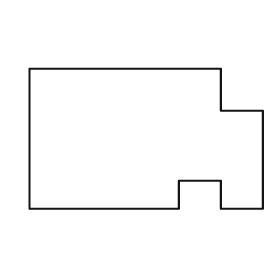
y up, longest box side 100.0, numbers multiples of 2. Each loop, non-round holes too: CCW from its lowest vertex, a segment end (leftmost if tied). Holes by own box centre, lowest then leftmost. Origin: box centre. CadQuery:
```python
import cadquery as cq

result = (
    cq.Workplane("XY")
    .moveTo(-50.0, -30.0)
    .lineTo(14.0, -30.0)
    .lineTo(14.0, -18.0)
    .lineTo(32.0, -18.0)
    .lineTo(32.0, -30.0)
    .lineTo(50.0, -30.0)
    .lineTo(50.0, 12.0)
    .lineTo(32.0, 12.0)
    .lineTo(32.0, 30.0)
    .lineTo(-50.0, 30.0)
    .close()
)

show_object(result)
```